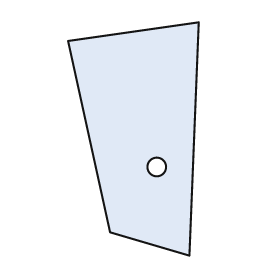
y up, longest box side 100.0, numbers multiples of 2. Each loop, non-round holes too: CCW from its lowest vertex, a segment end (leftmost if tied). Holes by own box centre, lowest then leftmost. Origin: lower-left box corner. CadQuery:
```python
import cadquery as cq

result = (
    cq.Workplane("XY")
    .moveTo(52.0, 0.0)
    .lineTo(56.0, 100.0)
    .lineTo(0.0, 92.0)
    .lineTo(18.0, 10.0)
    .close()
    .moveTo(38.0, 38.0)
    .circle(4.0)
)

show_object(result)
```